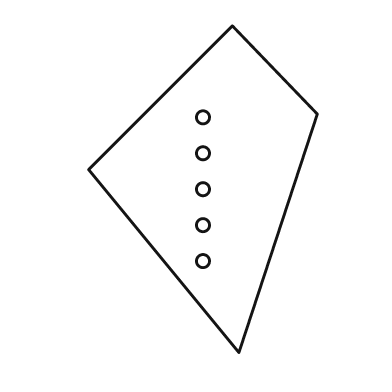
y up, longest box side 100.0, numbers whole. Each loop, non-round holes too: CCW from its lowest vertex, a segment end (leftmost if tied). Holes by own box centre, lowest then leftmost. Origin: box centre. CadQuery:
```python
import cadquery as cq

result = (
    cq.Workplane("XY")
    .moveTo(11.0, -50.0)
    .lineTo(35.0, 23.0)
    .lineTo(9.0, 50.0)
    .lineTo(-35.0, 6.0)
    .close()
    .moveTo(0.0, -22.0)
    .circle(2.0)
    .moveTo(0.0, -11.0)
    .circle(2.0)
    .moveTo(0.0, 0.0)
    .circle(2.0)
    .moveTo(0.0, 11.0)
    .circle(2.0)
    .moveTo(0.0, 22.0)
    .circle(2.0)
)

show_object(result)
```